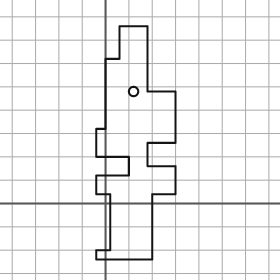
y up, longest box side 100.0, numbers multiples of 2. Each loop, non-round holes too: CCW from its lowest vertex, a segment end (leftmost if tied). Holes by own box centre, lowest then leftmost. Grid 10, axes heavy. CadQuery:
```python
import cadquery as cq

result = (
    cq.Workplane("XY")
    .moveTo(-4.0, -24.0)
    .lineTo(20.0, -24.0)
    .lineTo(20.0, 4.0)
    .lineTo(30.0, 4.0)
    .lineTo(30.0, 16.0)
    .lineTo(18.0, 16.0)
    .lineTo(18.0, 26.0)
    .lineTo(30.0, 26.0)
    .lineTo(30.0, 48.0)
    .lineTo(18.0, 48.0)
    .lineTo(18.0, 76.0)
    .lineTo(6.0, 76.0)
    .lineTo(6.0, 62.0)
    .lineTo(0.0, 62.0)
    .lineTo(0.0, 32.0)
    .lineTo(-4.0, 32.0)
    .lineTo(-4.0, 20.0)
    .lineTo(10.0, 20.0)
    .lineTo(10.0, 12.0)
    .lineTo(-4.0, 12.0)
    .lineTo(-4.0, 4.0)
    .lineTo(2.0, 4.0)
    .lineTo(2.0, -20.0)
    .lineTo(-4.0, -20.0)
    .close()
    .moveTo(12.0, 48.0)
    .circle(2.0)
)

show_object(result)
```